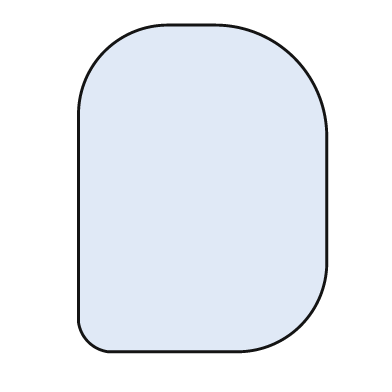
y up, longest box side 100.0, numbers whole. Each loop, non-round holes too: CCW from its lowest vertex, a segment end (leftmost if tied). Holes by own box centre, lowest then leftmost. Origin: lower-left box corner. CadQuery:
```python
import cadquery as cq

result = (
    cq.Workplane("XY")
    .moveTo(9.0, 0.0)
    .lineTo(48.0, 0.0)
    .threePointArc((68.0, 8.0), (76.0, 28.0))
    .lineTo(76.0, 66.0)
    .threePointArc((66.0, 90.0), (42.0, 100.0))
    .lineTo(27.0, 100.0)
    .threePointArc((8.0, 92.0), (0.0, 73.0))
    .lineTo(0.0, 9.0)
    .threePointArc((3.0, 3.0), (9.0, 0.0))
    .close()
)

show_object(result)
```